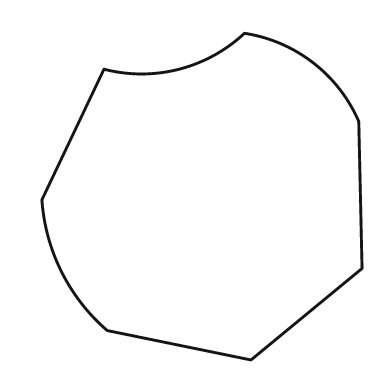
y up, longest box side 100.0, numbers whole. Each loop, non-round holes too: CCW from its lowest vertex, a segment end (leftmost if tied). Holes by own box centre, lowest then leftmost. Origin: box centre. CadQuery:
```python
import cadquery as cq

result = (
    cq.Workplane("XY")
    .moveTo(15.0, -50.0)
    .lineTo(49.0, -22.0)
    .lineTo(48.0, 23.0)
    .threePointArc((34.0, 41.0), (13.0, 50.0))
    .threePointArc((-7.0, 39.0), (-30.0, 39.0))
    .lineTo(-49.0, -1.0)
    .threePointArc((-43.0, -23.0), (-29.0, -41.0))
    .close()
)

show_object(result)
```